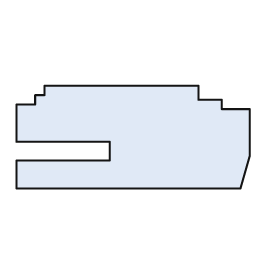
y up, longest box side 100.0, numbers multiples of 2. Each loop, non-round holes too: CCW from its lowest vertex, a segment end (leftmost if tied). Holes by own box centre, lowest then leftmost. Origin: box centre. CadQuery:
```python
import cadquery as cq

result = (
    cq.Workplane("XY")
    .moveTo(-50.0, -22.0)
    .lineTo(46.0, -22.0)
    .lineTo(50.0, -8.0)
    .lineTo(50.0, 12.0)
    .lineTo(38.0, 12.0)
    .lineTo(38.0, 16.0)
    .lineTo(28.0, 16.0)
    .lineTo(28.0, 22.0)
    .lineTo(-38.0, 22.0)
    .lineTo(-38.0, 18.0)
    .lineTo(-42.0, 18.0)
    .lineTo(-42.0, 14.0)
    .lineTo(-50.0, 14.0)
    .lineTo(-50.0, -2.0)
    .lineTo(-10.0, -2.0)
    .lineTo(-10.0, -10.0)
    .lineTo(-50.0, -10.0)
    .close()
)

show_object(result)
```